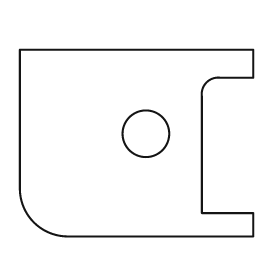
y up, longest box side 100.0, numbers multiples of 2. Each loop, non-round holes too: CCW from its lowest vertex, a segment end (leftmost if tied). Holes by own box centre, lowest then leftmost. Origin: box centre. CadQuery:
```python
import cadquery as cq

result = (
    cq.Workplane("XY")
    .moveTo(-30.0, -40.0)
    .lineTo(50.0, -40.0)
    .lineTo(50.0, -30.0)
    .lineTo(28.0, -30.0)
    .lineTo(28.0, 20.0)
    .threePointArc((30.0, 26.0), (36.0, 28.0))
    .lineTo(50.0, 28.0)
    .lineTo(50.0, 40.0)
    .lineTo(-50.0, 40.0)
    .lineTo(-50.0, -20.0)
    .threePointArc((-44.0, -34.0), (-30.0, -40.0))
    .close()
    .moveTo(4.0, 4.0)
    .circle(10.0)
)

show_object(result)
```